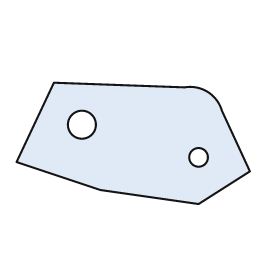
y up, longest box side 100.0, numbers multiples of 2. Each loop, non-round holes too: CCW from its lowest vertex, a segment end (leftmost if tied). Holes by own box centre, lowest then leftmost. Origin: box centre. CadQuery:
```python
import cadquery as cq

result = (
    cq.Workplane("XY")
    .moveTo(28.0, -26.0)
    .lineTo(50.0, -12.0)
    .lineTo(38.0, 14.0)
    .threePointArc((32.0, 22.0), (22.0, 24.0))
    .lineTo(-34.0, 26.0)
    .lineTo(-50.0, -8.0)
    .lineTo(-14.0, -20.0)
    .close()
    .moveTo(28.0, -6.0)
    .circle(4.0)
    .moveTo(-22.0, 8.0)
    .circle(6.0)
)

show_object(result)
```